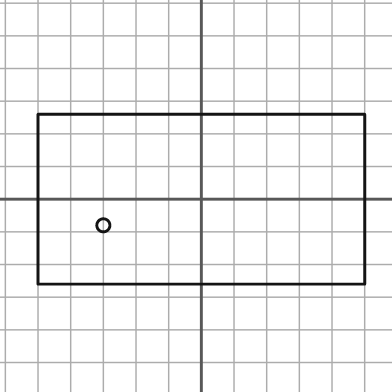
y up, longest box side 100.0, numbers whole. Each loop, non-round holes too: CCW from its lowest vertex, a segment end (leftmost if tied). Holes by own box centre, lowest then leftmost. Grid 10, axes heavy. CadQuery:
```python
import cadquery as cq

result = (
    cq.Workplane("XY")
    .moveTo(-50.0, -26.0)
    .lineTo(50.0, -26.0)
    .lineTo(50.0, 26.0)
    .lineTo(-50.0, 26.0)
    .close()
    .moveTo(-30.0, -8.0)
    .circle(2.0)
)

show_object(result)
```